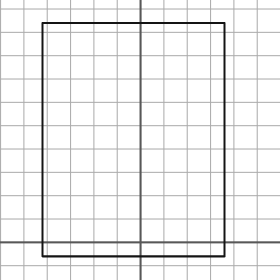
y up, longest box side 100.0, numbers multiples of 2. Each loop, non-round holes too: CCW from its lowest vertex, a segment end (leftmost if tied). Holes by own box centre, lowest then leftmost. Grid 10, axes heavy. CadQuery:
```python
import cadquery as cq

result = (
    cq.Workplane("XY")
    .moveTo(-42.0, -6.0)
    .lineTo(36.0, -6.0)
    .lineTo(36.0, 94.0)
    .lineTo(-42.0, 94.0)
    .close()
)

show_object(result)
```